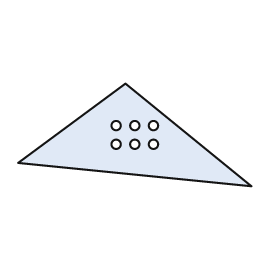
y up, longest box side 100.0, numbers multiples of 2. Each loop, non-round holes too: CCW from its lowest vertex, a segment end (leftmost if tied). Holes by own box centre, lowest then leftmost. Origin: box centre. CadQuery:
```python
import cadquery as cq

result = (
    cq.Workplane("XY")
    .moveTo(50.0, -22.0)
    .lineTo(-4.0, 22.0)
    .lineTo(-50.0, -12.0)
    .close()
    .moveTo(-8.0, -4.0)
    .circle(2.0)
    .moveTo(0.0, -4.0)
    .circle(2.0)
    .moveTo(8.0, -4.0)
    .circle(2.0)
    .moveTo(-8.0, 4.0)
    .circle(2.0)
    .moveTo(0.0, 4.0)
    .circle(2.0)
    .moveTo(8.0, 4.0)
    .circle(2.0)
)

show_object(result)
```